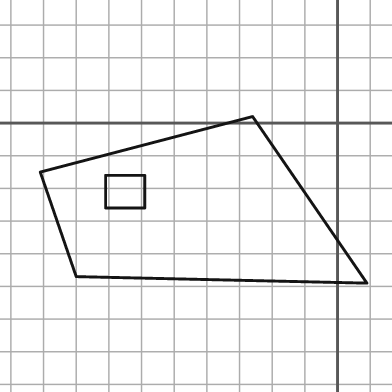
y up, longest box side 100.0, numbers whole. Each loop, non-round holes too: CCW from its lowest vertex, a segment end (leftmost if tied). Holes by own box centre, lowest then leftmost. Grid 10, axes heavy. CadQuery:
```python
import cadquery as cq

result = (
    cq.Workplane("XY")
    .moveTo(9.0, -49.0)
    .lineTo(-26.0, 2.0)
    .lineTo(-91.0, -15.0)
    .lineTo(-80.0, -47.0)
    .close()
    .moveTo(-71.0, -26.0)
    .lineTo(-59.0, -26.0)
    .lineTo(-59.0, -16.0)
    .lineTo(-71.0, -16.0)
    .close()
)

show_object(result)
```